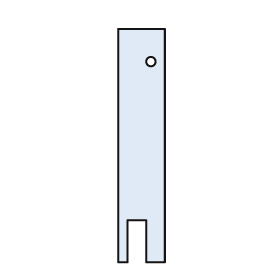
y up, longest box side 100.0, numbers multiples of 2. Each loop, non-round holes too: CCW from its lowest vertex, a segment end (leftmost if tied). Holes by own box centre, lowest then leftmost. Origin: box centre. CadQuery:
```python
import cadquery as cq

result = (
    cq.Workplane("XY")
    .moveTo(-10.0, -50.0)
    .lineTo(-6.0, -50.0)
    .lineTo(-6.0, -32.0)
    .lineTo(2.0, -32.0)
    .lineTo(2.0, -50.0)
    .lineTo(10.0, -50.0)
    .lineTo(10.0, 50.0)
    .lineTo(-10.0, 50.0)
    .close()
    .moveTo(4.0, 36.0)
    .circle(2.0)
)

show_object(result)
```